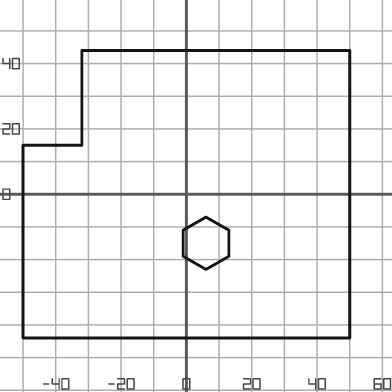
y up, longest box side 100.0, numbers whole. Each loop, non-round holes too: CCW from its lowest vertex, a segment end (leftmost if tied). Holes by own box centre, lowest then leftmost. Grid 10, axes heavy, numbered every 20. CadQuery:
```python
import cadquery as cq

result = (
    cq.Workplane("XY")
    .moveTo(-50.0, -44.0)
    .lineTo(50.0, -44.0)
    .lineTo(50.0, 44.0)
    .lineTo(-32.0, 44.0)
    .lineTo(-32.0, 15.0)
    .lineTo(-50.0, 15.0)
    .close()
    .moveTo(6.0, -23.0)
    .lineTo(13.0, -19.0)
    .lineTo(13.0, -11.0)
    .lineTo(6.0, -7.0)
    .lineTo(-1.0, -11.0)
    .lineTo(-1.0, -19.0)
    .close()
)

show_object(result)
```